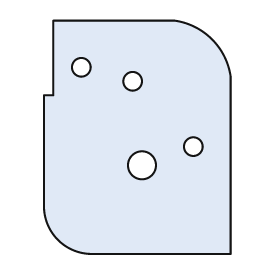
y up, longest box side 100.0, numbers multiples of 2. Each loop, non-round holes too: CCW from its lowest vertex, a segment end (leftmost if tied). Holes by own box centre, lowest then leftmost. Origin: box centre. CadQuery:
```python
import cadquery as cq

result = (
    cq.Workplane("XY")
    .moveTo(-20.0, -50.0)
    .lineTo(40.0, -50.0)
    .lineTo(40.0, 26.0)
    .threePointArc((32.0, 42.0), (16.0, 50.0))
    .lineTo(-36.0, 50.0)
    .lineTo(-36.0, 18.0)
    .lineTo(-40.0, 18.0)
    .lineTo(-40.0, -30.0)
    .threePointArc((-34.0, -44.0), (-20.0, -50.0))
    .close()
    .moveTo(2.0, -12.0)
    .circle(6.0)
    .moveTo(24.0, -4.0)
    .circle(4.0)
    .moveTo(-2.0, 24.0)
    .circle(4.0)
    .moveTo(-24.0, 30.0)
    .circle(4.0)
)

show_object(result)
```